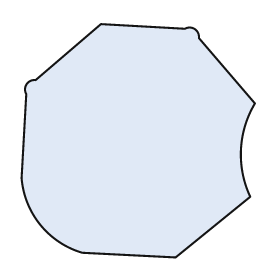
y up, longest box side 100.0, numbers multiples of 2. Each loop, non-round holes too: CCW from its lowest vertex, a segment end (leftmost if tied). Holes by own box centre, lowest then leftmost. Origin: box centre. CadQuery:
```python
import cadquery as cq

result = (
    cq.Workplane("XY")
    .moveTo(16.0, -50.0)
    .lineTo(48.0, -24.0)
    .threePointArc((44.0, -4.0), (50.0, 16.0))
    .lineTo(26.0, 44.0)
    .threePointArc((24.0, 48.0), (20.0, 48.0))
    .lineTo(-16.0, 50.0)
    .lineTo(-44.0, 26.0)
    .threePointArc((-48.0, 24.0), (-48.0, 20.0))
    .lineTo(-50.0, -16.0)
    .threePointArc((-42.0, -36.0), (-24.0, -48.0))
    .close()
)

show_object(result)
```